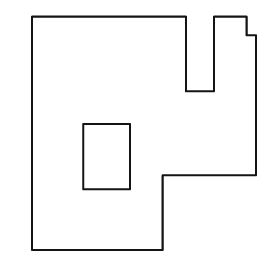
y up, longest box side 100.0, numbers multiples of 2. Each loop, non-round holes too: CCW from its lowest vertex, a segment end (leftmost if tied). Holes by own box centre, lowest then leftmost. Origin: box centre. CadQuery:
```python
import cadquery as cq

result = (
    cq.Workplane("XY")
    .moveTo(-48.0, -50.0)
    .lineTo(8.0, -50.0)
    .lineTo(8.0, -18.0)
    .lineTo(48.0, -18.0)
    .lineTo(48.0, 42.0)
    .lineTo(44.0, 42.0)
    .lineTo(44.0, 50.0)
    .lineTo(30.0, 50.0)
    .lineTo(30.0, 18.0)
    .lineTo(18.0, 18.0)
    .lineTo(18.0, 50.0)
    .lineTo(-48.0, 50.0)
    .close()
    .moveTo(-26.0, -24.0)
    .lineTo(-6.0, -24.0)
    .lineTo(-6.0, 4.0)
    .lineTo(-26.0, 4.0)
    .close()
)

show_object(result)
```